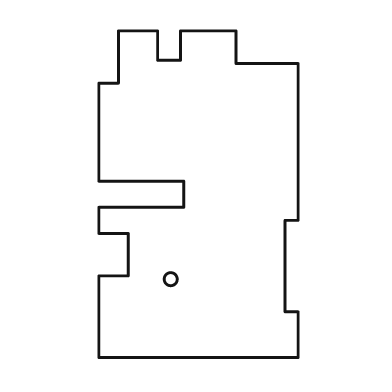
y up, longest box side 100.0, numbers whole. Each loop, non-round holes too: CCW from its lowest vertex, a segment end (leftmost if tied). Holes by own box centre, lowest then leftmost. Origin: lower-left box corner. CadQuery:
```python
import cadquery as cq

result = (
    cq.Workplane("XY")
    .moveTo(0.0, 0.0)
    .lineTo(61.0, 0.0)
    .lineTo(61.0, 14.0)
    .lineTo(57.0, 14.0)
    .lineTo(57.0, 42.0)
    .lineTo(61.0, 42.0)
    .lineTo(61.0, 90.0)
    .lineTo(42.0, 90.0)
    .lineTo(42.0, 100.0)
    .lineTo(25.0, 100.0)
    .lineTo(25.0, 91.0)
    .lineTo(18.0, 91.0)
    .lineTo(18.0, 100.0)
    .lineTo(6.0, 100.0)
    .lineTo(6.0, 84.0)
    .lineTo(0.0, 84.0)
    .lineTo(0.0, 54.0)
    .lineTo(26.0, 54.0)
    .lineTo(26.0, 46.0)
    .lineTo(0.0, 46.0)
    .lineTo(0.0, 38.0)
    .lineTo(9.0, 38.0)
    .lineTo(9.0, 25.0)
    .lineTo(0.0, 25.0)
    .close()
    .moveTo(22.0, 24.0)
    .circle(2.0)
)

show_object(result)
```